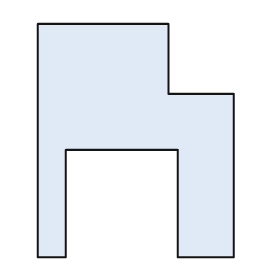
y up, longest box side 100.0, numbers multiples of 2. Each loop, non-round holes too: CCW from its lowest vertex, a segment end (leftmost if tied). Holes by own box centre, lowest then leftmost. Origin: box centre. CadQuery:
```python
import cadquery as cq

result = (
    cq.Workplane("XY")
    .moveTo(-42.0, -50.0)
    .lineTo(-30.0, -50.0)
    .lineTo(-30.0, -4.0)
    .lineTo(18.0, -4.0)
    .lineTo(18.0, -50.0)
    .lineTo(42.0, -50.0)
    .lineTo(42.0, 20.0)
    .lineTo(14.0, 20.0)
    .lineTo(14.0, 50.0)
    .lineTo(-42.0, 50.0)
    .close()
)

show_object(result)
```